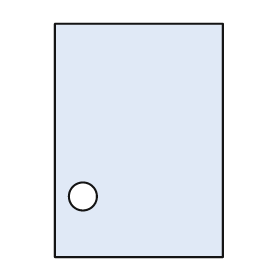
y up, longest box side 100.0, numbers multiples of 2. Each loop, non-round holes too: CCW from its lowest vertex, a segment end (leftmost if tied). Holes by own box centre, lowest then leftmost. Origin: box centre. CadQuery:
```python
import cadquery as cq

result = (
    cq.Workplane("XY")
    .moveTo(-36.0, -50.0)
    .lineTo(36.0, -50.0)
    .lineTo(36.0, 50.0)
    .lineTo(-36.0, 50.0)
    .close()
    .moveTo(-24.0, -24.0)
    .circle(6.0)
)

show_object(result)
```